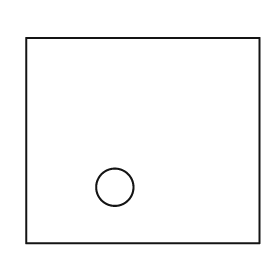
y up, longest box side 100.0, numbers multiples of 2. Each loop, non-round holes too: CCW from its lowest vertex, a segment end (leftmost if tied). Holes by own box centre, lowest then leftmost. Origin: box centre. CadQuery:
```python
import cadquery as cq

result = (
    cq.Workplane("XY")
    .moveTo(-50.0, -44.0)
    .lineTo(50.0, -44.0)
    .lineTo(50.0, 44.0)
    .lineTo(-50.0, 44.0)
    .close()
    .moveTo(-12.0, -20.0)
    .circle(8.0)
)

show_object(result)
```